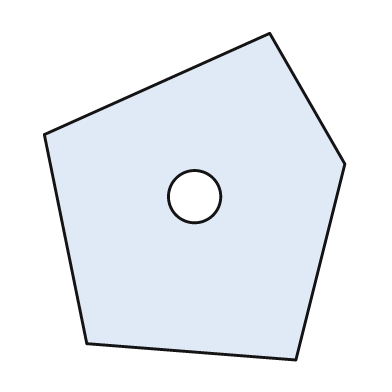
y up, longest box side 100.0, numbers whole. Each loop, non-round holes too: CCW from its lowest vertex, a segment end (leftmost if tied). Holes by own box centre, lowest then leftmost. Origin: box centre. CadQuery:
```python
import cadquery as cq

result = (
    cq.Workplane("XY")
    .moveTo(31.0, -50.0)
    .lineTo(46.0, 10.0)
    .lineTo(23.0, 50.0)
    .lineTo(-46.0, 19.0)
    .lineTo(-33.0, -45.0)
    .close()
    .moveTo(0.0, 0.0)
    .circle(8.0)
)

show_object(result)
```